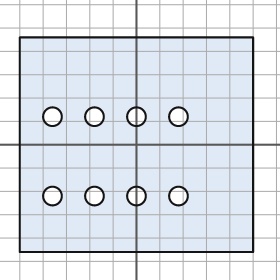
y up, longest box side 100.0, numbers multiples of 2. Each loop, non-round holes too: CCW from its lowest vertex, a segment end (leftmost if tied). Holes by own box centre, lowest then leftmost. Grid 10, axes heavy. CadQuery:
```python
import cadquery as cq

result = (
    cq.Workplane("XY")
    .moveTo(-50.0, -46.0)
    .lineTo(50.0, -46.0)
    .lineTo(50.0, 46.0)
    .lineTo(-50.0, 46.0)
    .close()
    .moveTo(-36.0, -22.0)
    .circle(4.0)
    .moveTo(-18.0, -22.0)
    .circle(4.0)
    .moveTo(0.0, -22.0)
    .circle(4.0)
    .moveTo(18.0, -22.0)
    .circle(4.0)
    .moveTo(-36.0, 12.0)
    .circle(4.0)
    .moveTo(-18.0, 12.0)
    .circle(4.0)
    .moveTo(0.0, 12.0)
    .circle(4.0)
    .moveTo(18.0, 12.0)
    .circle(4.0)
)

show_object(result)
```